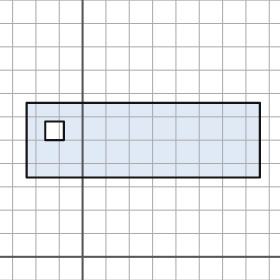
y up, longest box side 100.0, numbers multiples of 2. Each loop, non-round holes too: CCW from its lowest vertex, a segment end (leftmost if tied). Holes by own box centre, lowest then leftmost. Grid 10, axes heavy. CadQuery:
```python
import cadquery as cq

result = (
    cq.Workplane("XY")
    .moveTo(-24.0, 34.0)
    .lineTo(76.0, 34.0)
    .lineTo(76.0, 66.0)
    .lineTo(-24.0, 66.0)
    .close()
    .moveTo(-16.0, 50.0)
    .lineTo(-8.0, 50.0)
    .lineTo(-8.0, 58.0)
    .lineTo(-16.0, 58.0)
    .close()
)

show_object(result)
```